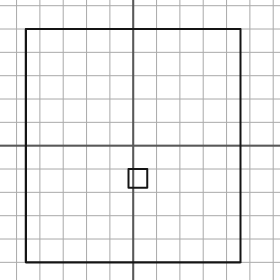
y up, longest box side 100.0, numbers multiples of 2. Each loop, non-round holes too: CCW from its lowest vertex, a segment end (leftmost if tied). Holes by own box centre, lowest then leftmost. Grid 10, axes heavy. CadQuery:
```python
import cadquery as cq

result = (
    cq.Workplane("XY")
    .moveTo(-46.0, -50.0)
    .lineTo(46.0, -50.0)
    .lineTo(46.0, 50.0)
    .lineTo(-46.0, 50.0)
    .close()
    .moveTo(-2.0, -18.0)
    .lineTo(6.0, -18.0)
    .lineTo(6.0, -10.0)
    .lineTo(-2.0, -10.0)
    .close()
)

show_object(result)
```